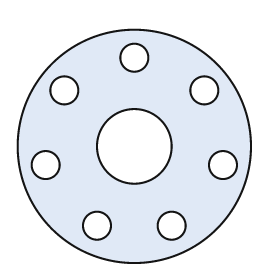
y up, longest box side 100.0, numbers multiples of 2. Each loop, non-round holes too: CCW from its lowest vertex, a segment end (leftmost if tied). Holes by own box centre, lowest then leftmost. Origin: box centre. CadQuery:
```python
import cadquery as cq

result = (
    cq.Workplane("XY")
    .moveTo(0.0, 0.0)
    .circle(50.0)
    .moveTo(-16.0, -34.0)
    .circle(6.0)
    .moveTo(16.0, -34.0)
    .circle(6.0)
    .moveTo(-38.0, -8.0)
    .circle(6.0)
    .moveTo(38.0, -8.0)
    .circle(6.0)
    .moveTo(0.0, 0.0)
    .circle(16.0)
    .moveTo(-30.0, 24.0)
    .circle(6.0)
    .moveTo(30.0, 24.0)
    .circle(6.0)
    .moveTo(0.0, 38.0)
    .circle(6.0)
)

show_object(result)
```